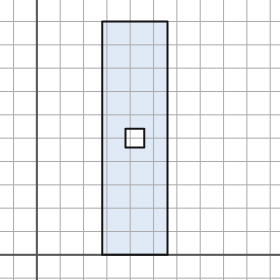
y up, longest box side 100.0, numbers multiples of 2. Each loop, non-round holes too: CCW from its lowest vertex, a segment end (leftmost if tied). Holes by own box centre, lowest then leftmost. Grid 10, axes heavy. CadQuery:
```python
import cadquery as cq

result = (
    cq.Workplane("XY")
    .moveTo(28.0, 0.0)
    .lineTo(56.0, 0.0)
    .lineTo(56.0, 100.0)
    .lineTo(28.0, 100.0)
    .close()
    .moveTo(38.0, 46.0)
    .lineTo(46.0, 46.0)
    .lineTo(46.0, 54.0)
    .lineTo(38.0, 54.0)
    .close()
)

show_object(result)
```